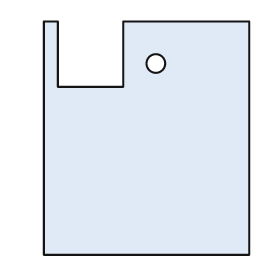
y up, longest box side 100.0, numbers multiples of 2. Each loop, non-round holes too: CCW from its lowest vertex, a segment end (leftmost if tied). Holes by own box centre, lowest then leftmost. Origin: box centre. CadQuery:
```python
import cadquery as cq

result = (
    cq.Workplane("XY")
    .moveTo(-44.0, -50.0)
    .lineTo(44.0, -50.0)
    .lineTo(44.0, 50.0)
    .lineTo(-10.0, 50.0)
    .lineTo(-10.0, 22.0)
    .lineTo(-38.0, 22.0)
    .lineTo(-38.0, 50.0)
    .lineTo(-44.0, 50.0)
    .close()
    .moveTo(4.0, 32.0)
    .circle(4.0)
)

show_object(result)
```